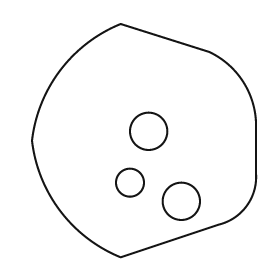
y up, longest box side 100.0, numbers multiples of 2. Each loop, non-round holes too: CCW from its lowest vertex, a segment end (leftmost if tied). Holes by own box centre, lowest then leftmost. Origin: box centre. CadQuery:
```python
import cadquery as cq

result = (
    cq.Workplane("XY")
    .moveTo(-10.0, -50.0)
    .lineTo(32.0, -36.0)
    .threePointArc((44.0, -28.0), (48.0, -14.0))
    .lineTo(48.0, 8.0)
    .threePointArc((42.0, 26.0), (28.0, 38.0))
    .lineTo(-10.0, 50.0)
    .threePointArc((-36.0, 30.0), (-48.0, 0.0))
    .threePointArc((-36.0, -30.0), (-10.0, -50.0))
    .close()
    .moveTo(16.0, -26.0)
    .circle(8.0)
    .moveTo(-6.0, -18.0)
    .circle(6.0)
    .moveTo(2.0, 4.0)
    .circle(8.0)
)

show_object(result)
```